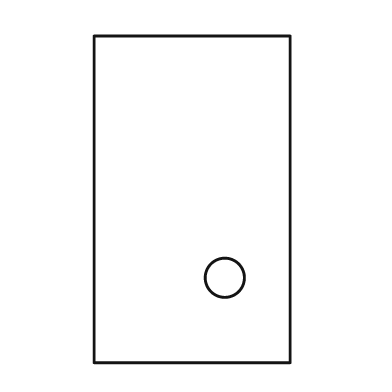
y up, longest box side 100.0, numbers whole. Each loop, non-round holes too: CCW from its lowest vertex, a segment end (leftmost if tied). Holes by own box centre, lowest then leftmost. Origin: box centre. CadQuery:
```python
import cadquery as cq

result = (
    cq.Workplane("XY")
    .moveTo(-30.0, -50.0)
    .lineTo(30.0, -50.0)
    .lineTo(30.0, 50.0)
    .lineTo(-30.0, 50.0)
    .close()
    .moveTo(10.0, -24.0)
    .circle(6.0)
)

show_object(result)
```